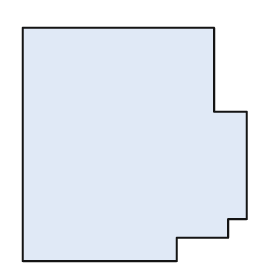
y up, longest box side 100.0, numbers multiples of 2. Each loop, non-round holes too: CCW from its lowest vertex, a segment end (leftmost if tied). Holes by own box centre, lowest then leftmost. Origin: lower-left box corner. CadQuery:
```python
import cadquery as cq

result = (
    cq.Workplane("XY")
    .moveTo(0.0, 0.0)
    .lineTo(66.0, 0.0)
    .lineTo(66.0, 10.0)
    .lineTo(88.0, 10.0)
    .lineTo(88.0, 18.0)
    .lineTo(96.0, 18.0)
    .lineTo(96.0, 64.0)
    .lineTo(82.0, 64.0)
    .lineTo(82.0, 100.0)
    .lineTo(0.0, 100.0)
    .close()
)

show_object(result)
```